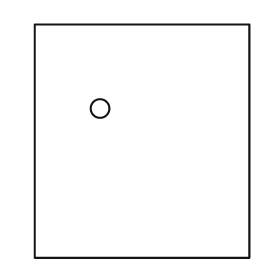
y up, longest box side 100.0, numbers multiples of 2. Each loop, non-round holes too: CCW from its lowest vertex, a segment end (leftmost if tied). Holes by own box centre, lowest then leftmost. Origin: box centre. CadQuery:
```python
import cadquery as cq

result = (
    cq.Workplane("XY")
    .moveTo(-46.0, -50.0)
    .lineTo(46.0, -50.0)
    .lineTo(46.0, 50.0)
    .lineTo(-46.0, 50.0)
    .close()
    .moveTo(-18.0, 14.0)
    .circle(4.0)
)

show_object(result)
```